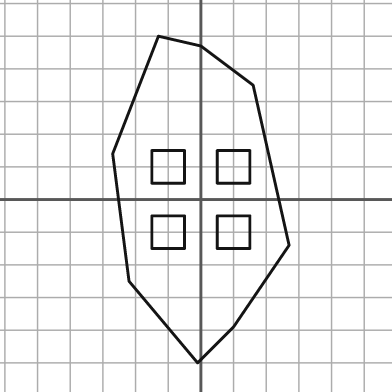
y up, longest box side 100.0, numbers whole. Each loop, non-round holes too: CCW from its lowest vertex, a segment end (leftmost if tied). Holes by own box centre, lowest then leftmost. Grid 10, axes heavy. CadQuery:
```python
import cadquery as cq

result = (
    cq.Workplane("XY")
    .moveTo(-1.0, -50.0)
    .lineTo(10.0, -39.0)
    .lineTo(27.0, -14.0)
    .lineTo(16.0, 35.0)
    .lineTo(0.0, 47.0)
    .lineTo(-13.0, 50.0)
    .lineTo(-27.0, 14.0)
    .lineTo(-22.0, -25.0)
    .close()
    .moveTo(-15.0, -15.0)
    .lineTo(-5.0, -15.0)
    .lineTo(-5.0, -5.0)
    .lineTo(-15.0, -5.0)
    .close()
    .moveTo(5.0, -15.0)
    .lineTo(15.0, -15.0)
    .lineTo(15.0, -5.0)
    .lineTo(5.0, -5.0)
    .close()
    .moveTo(-15.0, 5.0)
    .lineTo(-5.0, 5.0)
    .lineTo(-5.0, 15.0)
    .lineTo(-15.0, 15.0)
    .close()
    .moveTo(5.0, 5.0)
    .lineTo(15.0, 5.0)
    .lineTo(15.0, 15.0)
    .lineTo(5.0, 15.0)
    .close()
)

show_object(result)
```